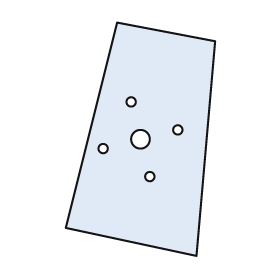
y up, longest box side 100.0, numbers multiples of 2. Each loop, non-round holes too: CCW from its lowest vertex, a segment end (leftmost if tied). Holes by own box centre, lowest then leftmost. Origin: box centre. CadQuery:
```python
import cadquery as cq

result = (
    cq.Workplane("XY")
    .moveTo(24.0, -50.0)
    .lineTo(32.0, 42.0)
    .lineTo(-10.0, 50.0)
    .lineTo(-32.0, -38.0)
    .close()
    .moveTo(4.0, -16.0)
    .circle(2.0)
    .moveTo(-16.0, -4.0)
    .circle(2.0)
    .moveTo(0.0, 0.0)
    .circle(4.0)
    .moveTo(16.0, 4.0)
    .circle(2.0)
    .moveTo(-4.0, 16.0)
    .circle(2.0)
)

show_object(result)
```